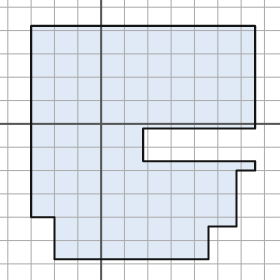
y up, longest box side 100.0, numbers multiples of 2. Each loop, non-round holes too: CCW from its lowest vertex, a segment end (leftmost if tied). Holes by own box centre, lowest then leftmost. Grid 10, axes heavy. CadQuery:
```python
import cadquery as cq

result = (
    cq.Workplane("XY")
    .moveTo(-20.0, -58.0)
    .lineTo(46.0, -58.0)
    .lineTo(46.0, -44.0)
    .lineTo(58.0, -44.0)
    .lineTo(58.0, -20.0)
    .lineTo(66.0, -20.0)
    .lineTo(66.0, -16.0)
    .lineTo(18.0, -16.0)
    .lineTo(18.0, -2.0)
    .lineTo(66.0, -2.0)
    .lineTo(66.0, 42.0)
    .lineTo(-30.0, 42.0)
    .lineTo(-30.0, -40.0)
    .lineTo(-20.0, -40.0)
    .close()
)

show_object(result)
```